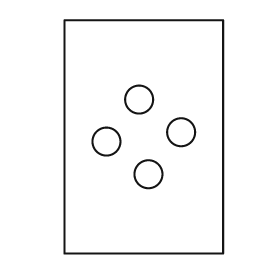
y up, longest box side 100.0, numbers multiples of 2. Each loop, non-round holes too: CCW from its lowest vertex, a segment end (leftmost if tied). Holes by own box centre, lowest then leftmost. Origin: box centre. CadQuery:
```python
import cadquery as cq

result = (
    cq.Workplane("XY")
    .moveTo(-34.0, -50.0)
    .lineTo(34.0, -50.0)
    .lineTo(34.0, 50.0)
    .lineTo(-34.0, 50.0)
    .close()
    .moveTo(2.0, -16.0)
    .circle(6.0)
    .moveTo(-16.0, -2.0)
    .circle(6.0)
    .moveTo(16.0, 2.0)
    .circle(6.0)
    .moveTo(-2.0, 16.0)
    .circle(6.0)
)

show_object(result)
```